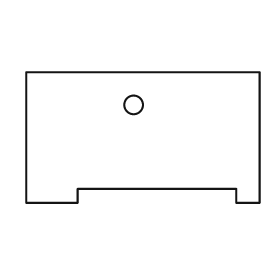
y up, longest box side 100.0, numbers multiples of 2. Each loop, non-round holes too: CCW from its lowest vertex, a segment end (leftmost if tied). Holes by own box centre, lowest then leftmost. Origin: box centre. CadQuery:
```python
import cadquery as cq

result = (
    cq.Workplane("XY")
    .moveTo(-50.0, -28.0)
    .lineTo(-28.0, -28.0)
    .lineTo(-28.0, -22.0)
    .lineTo(40.0, -22.0)
    .lineTo(40.0, -28.0)
    .lineTo(50.0, -28.0)
    .lineTo(50.0, 28.0)
    .lineTo(-50.0, 28.0)
    .close()
    .moveTo(-4.0, 14.0)
    .circle(4.0)
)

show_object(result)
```